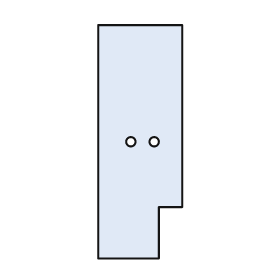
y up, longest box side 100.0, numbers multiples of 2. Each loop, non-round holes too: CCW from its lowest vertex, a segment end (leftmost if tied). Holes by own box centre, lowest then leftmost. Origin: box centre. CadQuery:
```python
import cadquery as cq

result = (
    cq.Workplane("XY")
    .moveTo(-18.0, -50.0)
    .lineTo(8.0, -50.0)
    .lineTo(8.0, -28.0)
    .lineTo(18.0, -28.0)
    .lineTo(18.0, 50.0)
    .lineTo(-18.0, 50.0)
    .close()
    .moveTo(-4.0, 0.0)
    .circle(2.0)
    .moveTo(6.0, 0.0)
    .circle(2.0)
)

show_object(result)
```